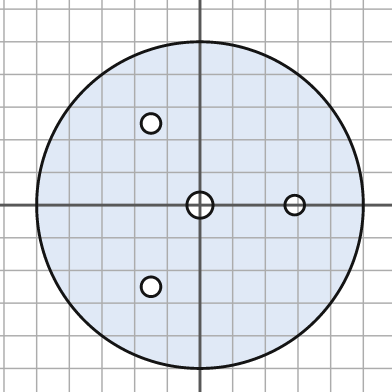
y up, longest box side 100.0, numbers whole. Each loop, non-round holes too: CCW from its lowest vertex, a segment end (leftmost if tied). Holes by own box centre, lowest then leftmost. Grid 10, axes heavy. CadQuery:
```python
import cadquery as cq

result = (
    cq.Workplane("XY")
    .moveTo(0.0, 0.0)
    .circle(50.0)
    .moveTo(-15.0, -25.0)
    .circle(3.0)
    .moveTo(0.0, 0.0)
    .circle(4.0)
    .moveTo(29.0, 0.0)
    .circle(3.0)
    .moveTo(-15.0, 25.0)
    .circle(3.0)
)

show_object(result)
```